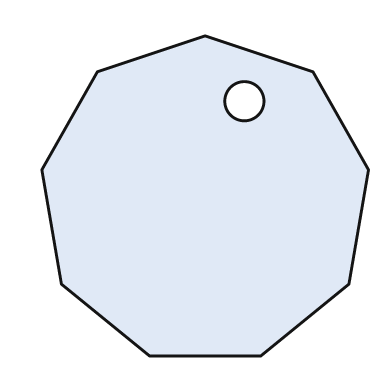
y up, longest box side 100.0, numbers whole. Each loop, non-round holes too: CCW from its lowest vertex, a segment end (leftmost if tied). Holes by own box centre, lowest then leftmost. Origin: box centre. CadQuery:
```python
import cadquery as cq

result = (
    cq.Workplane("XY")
    .moveTo(-17.0, -49.0)
    .lineTo(17.0, -49.0)
    .lineTo(44.0, -27.0)
    .lineTo(50.0, 8.0)
    .lineTo(33.0, 38.0)
    .lineTo(0.0, 49.0)
    .lineTo(-33.0, 38.0)
    .lineTo(-50.0, 8.0)
    .lineTo(-44.0, -27.0)
    .close()
    .moveTo(12.0, 29.0)
    .circle(6.0)
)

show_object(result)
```